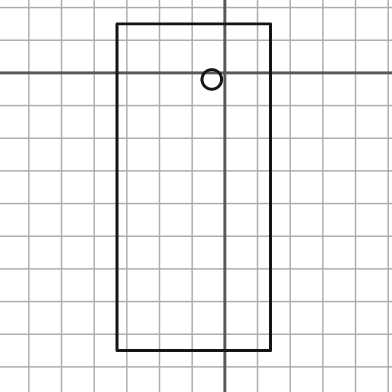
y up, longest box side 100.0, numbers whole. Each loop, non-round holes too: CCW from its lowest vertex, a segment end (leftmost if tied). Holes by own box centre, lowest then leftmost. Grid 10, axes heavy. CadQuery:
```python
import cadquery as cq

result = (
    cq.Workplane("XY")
    .moveTo(-33.0, -85.0)
    .lineTo(14.0, -85.0)
    .lineTo(14.0, 15.0)
    .lineTo(-33.0, 15.0)
    .close()
    .moveTo(-4.0, -2.0)
    .circle(3.0)
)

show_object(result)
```